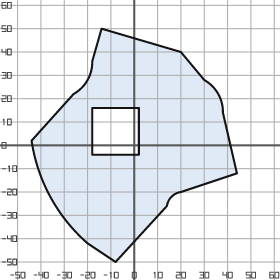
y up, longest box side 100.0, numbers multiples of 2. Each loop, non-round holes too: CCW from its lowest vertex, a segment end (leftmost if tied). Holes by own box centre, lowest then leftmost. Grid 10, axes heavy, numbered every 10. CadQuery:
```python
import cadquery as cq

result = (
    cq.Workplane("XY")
    .moveTo(-8.0, -50.0)
    .lineTo(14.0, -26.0)
    .threePointArc((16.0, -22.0), (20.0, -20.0))
    .lineTo(44.0, -12.0)
    .lineTo(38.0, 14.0)
    .threePointArc((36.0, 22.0), (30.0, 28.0))
    .lineTo(20.0, 40.0)
    .lineTo(-14.0, 50.0)
    .lineTo(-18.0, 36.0)
    .threePointArc((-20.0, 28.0), (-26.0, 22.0))
    .lineTo(-44.0, 2.0)
    .threePointArc((-36.0, -22.0), (-20.0, -42.0))
    .close()
    .moveTo(-18.0, -4.0)
    .lineTo(2.0, -4.0)
    .lineTo(2.0, 16.0)
    .lineTo(-18.0, 16.0)
    .close()
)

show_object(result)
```